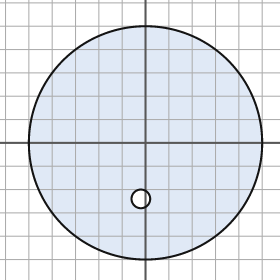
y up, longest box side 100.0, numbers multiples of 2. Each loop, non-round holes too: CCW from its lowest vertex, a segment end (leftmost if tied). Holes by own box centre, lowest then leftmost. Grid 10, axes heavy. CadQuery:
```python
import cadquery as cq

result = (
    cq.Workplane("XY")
    .moveTo(0.0, 0.0)
    .circle(50.0)
    .moveTo(-2.0, -24.0)
    .circle(4.0)
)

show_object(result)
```